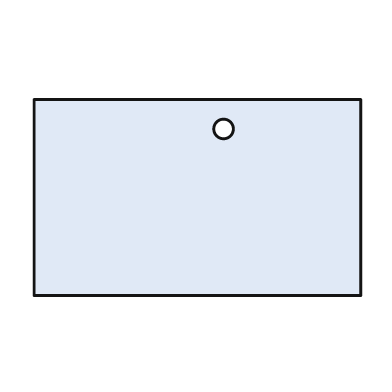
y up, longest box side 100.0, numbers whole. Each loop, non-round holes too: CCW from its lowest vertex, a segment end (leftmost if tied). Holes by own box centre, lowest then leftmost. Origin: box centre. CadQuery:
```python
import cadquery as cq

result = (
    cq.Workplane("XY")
    .moveTo(-50.0, -30.0)
    .lineTo(50.0, -30.0)
    .lineTo(50.0, 30.0)
    .lineTo(-50.0, 30.0)
    .close()
    .moveTo(8.0, 21.0)
    .circle(3.0)
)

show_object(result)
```